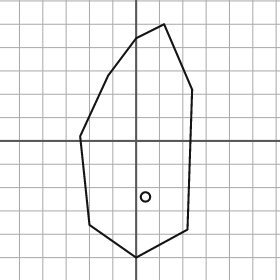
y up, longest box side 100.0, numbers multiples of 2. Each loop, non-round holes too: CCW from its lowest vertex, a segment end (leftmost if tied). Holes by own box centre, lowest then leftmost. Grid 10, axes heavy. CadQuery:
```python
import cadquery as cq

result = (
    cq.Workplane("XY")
    .moveTo(0.0, -50.0)
    .lineTo(22.0, -38.0)
    .lineTo(24.0, 22.0)
    .lineTo(12.0, 50.0)
    .lineTo(0.0, 44.0)
    .lineTo(-12.0, 28.0)
    .lineTo(-24.0, 2.0)
    .lineTo(-20.0, -36.0)
    .close()
    .moveTo(4.0, -24.0)
    .circle(2.0)
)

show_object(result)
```